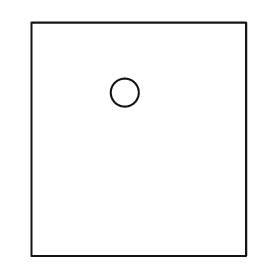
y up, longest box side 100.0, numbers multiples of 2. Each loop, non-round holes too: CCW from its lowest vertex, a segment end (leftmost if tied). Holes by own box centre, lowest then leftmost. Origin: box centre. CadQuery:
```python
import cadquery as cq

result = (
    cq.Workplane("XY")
    .moveTo(-46.0, -50.0)
    .lineTo(46.0, -50.0)
    .lineTo(46.0, 50.0)
    .lineTo(-46.0, 50.0)
    .close()
    .moveTo(-6.0, 20.0)
    .circle(6.0)
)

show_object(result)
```